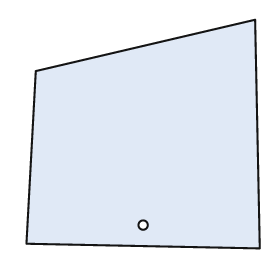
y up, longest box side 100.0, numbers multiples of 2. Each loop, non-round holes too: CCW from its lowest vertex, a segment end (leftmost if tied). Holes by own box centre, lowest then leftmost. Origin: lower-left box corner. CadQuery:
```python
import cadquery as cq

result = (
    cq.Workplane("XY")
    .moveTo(100.0, 0.0)
    .lineTo(98.0, 98.0)
    .lineTo(4.0, 76.0)
    .lineTo(0.0, 2.0)
    .close()
    .moveTo(50.0, 10.0)
    .circle(2.0)
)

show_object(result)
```